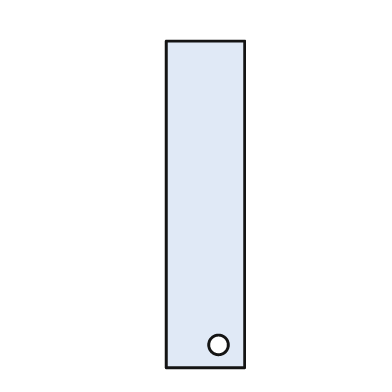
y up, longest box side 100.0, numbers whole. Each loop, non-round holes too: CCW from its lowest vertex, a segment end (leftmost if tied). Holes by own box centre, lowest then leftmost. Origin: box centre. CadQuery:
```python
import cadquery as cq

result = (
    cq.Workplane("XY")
    .moveTo(-12.0, -50.0)
    .lineTo(12.0, -50.0)
    .lineTo(12.0, 50.0)
    .lineTo(-12.0, 50.0)
    .close()
    .moveTo(4.0, -43.0)
    .circle(3.0)
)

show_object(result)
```